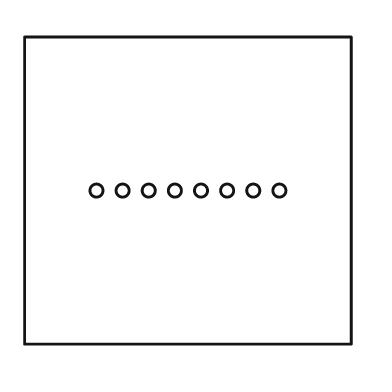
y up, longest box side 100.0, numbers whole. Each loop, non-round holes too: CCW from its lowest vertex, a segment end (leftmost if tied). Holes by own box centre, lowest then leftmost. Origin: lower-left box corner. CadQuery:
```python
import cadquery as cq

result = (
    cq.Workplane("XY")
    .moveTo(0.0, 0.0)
    .lineTo(100.0, 0.0)
    .lineTo(100.0, 94.0)
    .lineTo(0.0, 94.0)
    .close()
    .moveTo(22.0, 47.0)
    .circle(2.0)
    .moveTo(30.0, 47.0)
    .circle(2.0)
    .moveTo(38.0, 47.0)
    .circle(2.0)
    .moveTo(46.0, 47.0)
    .circle(2.0)
    .moveTo(54.0, 47.0)
    .circle(2.0)
    .moveTo(62.0, 47.0)
    .circle(2.0)
    .moveTo(70.0, 47.0)
    .circle(2.0)
    .moveTo(78.0, 47.0)
    .circle(2.0)
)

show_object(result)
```